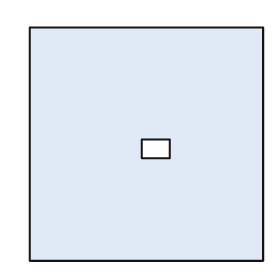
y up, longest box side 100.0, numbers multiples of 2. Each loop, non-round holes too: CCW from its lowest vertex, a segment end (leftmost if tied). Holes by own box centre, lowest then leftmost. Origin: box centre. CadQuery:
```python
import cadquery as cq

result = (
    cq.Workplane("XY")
    .moveTo(-50.0, -50.0)
    .lineTo(50.0, -50.0)
    .lineTo(50.0, 50.0)
    .lineTo(-50.0, 50.0)
    .close()
    .moveTo(-2.0, -6.0)
    .lineTo(10.0, -6.0)
    .lineTo(10.0, 2.0)
    .lineTo(-2.0, 2.0)
    .close()
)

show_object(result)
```